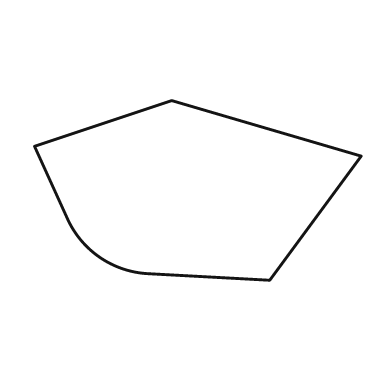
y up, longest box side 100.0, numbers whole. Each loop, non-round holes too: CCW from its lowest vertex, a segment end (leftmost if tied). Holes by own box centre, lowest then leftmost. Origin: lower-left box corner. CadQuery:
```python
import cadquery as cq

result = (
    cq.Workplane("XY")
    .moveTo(72.0, 0.0)
    .lineTo(100.0, 38.0)
    .lineTo(42.0, 55.0)
    .lineTo(0.0, 41.0)
    .lineTo(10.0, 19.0)
    .threePointArc((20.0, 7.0), (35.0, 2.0))
    .close()
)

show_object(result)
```